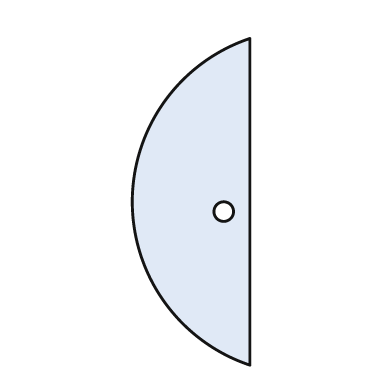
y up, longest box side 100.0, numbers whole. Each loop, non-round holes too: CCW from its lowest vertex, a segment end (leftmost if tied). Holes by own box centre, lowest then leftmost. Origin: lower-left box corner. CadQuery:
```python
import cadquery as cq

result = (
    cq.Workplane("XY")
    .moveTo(36.0, 0.0)
    .lineTo(36.0, 100.0)
    .threePointArc((0.0, 50.0), (36.0, 0.0))
    .close()
    .moveTo(28.0, 47.0)
    .circle(3.0)
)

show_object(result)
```